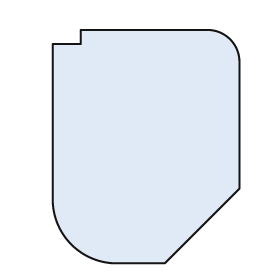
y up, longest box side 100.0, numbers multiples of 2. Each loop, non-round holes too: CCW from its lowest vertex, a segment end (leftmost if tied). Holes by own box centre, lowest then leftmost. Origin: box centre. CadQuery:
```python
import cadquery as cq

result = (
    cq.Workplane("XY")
    .moveTo(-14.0, -50.0)
    .lineTo(8.0, -50.0)
    .lineTo(40.0, -18.0)
    .lineTo(40.0, 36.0)
    .threePointArc((36.0, 46.0), (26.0, 50.0))
    .lineTo(-28.0, 50.0)
    .lineTo(-28.0, 44.0)
    .lineTo(-40.0, 44.0)
    .lineTo(-40.0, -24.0)
    .threePointArc((-32.0, -42.0), (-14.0, -50.0))
    .close()
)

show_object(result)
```